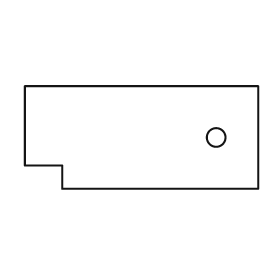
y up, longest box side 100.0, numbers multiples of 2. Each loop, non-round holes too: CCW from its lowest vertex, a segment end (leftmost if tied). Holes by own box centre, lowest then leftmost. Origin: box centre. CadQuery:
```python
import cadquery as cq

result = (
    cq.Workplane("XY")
    .moveTo(-34.0, -22.0)
    .lineTo(50.0, -22.0)
    .lineTo(50.0, 22.0)
    .lineTo(-50.0, 22.0)
    .lineTo(-50.0, -12.0)
    .lineTo(-34.0, -12.0)
    .close()
    .moveTo(32.0, 0.0)
    .circle(4.0)
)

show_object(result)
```